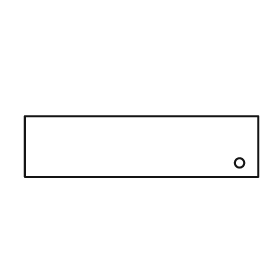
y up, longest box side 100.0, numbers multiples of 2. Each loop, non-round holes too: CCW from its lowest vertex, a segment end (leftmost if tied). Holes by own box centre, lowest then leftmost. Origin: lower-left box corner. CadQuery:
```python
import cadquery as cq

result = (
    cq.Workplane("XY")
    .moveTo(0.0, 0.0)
    .lineTo(100.0, 0.0)
    .lineTo(100.0, 26.0)
    .lineTo(0.0, 26.0)
    .close()
    .moveTo(92.0, 6.0)
    .circle(2.0)
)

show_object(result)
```